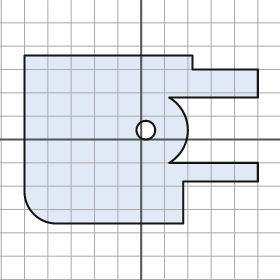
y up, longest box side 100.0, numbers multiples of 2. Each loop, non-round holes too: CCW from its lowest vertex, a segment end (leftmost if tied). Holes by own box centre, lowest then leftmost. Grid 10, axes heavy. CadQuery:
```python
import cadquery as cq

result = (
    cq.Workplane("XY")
    .moveTo(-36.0, -36.0)
    .lineTo(18.0, -36.0)
    .lineTo(18.0, -18.0)
    .lineTo(50.0, -18.0)
    .lineTo(50.0, -10.0)
    .lineTo(12.0, -10.0)
    .threePointArc((20.0, 4.0), (12.0, 18.0))
    .lineTo(50.0, 18.0)
    .lineTo(50.0, 30.0)
    .lineTo(22.0, 30.0)
    .lineTo(22.0, 36.0)
    .lineTo(-50.0, 36.0)
    .lineTo(-50.0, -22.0)
    .threePointArc((-46.0, -32.0), (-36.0, -36.0))
    .close()
    .moveTo(2.0, 4.0)
    .circle(4.0)
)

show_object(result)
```